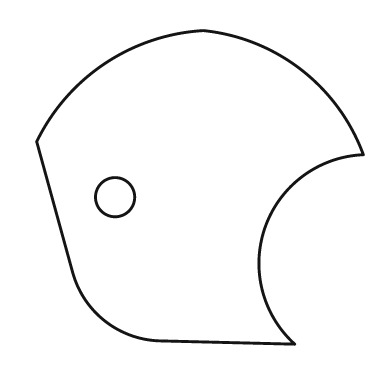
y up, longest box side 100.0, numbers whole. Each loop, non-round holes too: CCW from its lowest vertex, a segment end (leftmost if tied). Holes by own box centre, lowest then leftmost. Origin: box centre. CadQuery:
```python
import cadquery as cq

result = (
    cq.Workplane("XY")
    .moveTo(29.0, -48.0)
    .threePointArc((20.0, -12.0), (50.0, 10.0))
    .threePointArc((31.0, 36.0), (1.0, 48.0))
    .threePointArc((-29.0, 38.0), (-50.0, 14.0))
    .lineTo(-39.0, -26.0)
    .threePointArc((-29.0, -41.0), (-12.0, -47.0))
    .close()
    .moveTo(-26.0, -3.0)
    .circle(6.0)
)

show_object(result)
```